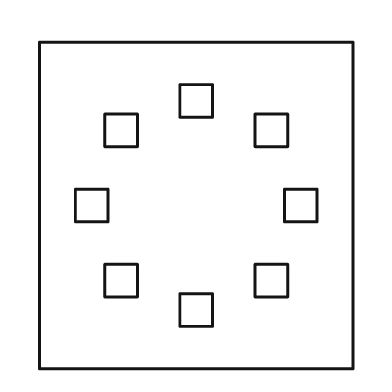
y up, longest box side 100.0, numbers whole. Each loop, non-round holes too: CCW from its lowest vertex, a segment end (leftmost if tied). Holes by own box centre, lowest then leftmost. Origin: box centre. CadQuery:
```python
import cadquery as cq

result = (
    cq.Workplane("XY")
    .moveTo(-48.0, -50.0)
    .lineTo(48.0, -50.0)
    .lineTo(48.0, 50.0)
    .lineTo(-48.0, 50.0)
    .close()
    .moveTo(-5.0, -37.0)
    .lineTo(5.0, -37.0)
    .lineTo(5.0, -27.0)
    .lineTo(-5.0, -27.0)
    .close()
    .moveTo(-28.0, -28.0)
    .lineTo(-18.0, -28.0)
    .lineTo(-18.0, -18.0)
    .lineTo(-28.0, -18.0)
    .close()
    .moveTo(18.0, -28.0)
    .lineTo(28.0, -28.0)
    .lineTo(28.0, -18.0)
    .lineTo(18.0, -18.0)
    .close()
    .moveTo(-37.0, -5.0)
    .lineTo(-27.0, -5.0)
    .lineTo(-27.0, 5.0)
    .lineTo(-37.0, 5.0)
    .close()
    .moveTo(27.0, -5.0)
    .lineTo(37.0, -5.0)
    .lineTo(37.0, 5.0)
    .lineTo(27.0, 5.0)
    .close()
    .moveTo(-28.0, 18.0)
    .lineTo(-18.0, 18.0)
    .lineTo(-18.0, 28.0)
    .lineTo(-28.0, 28.0)
    .close()
    .moveTo(18.0, 18.0)
    .lineTo(28.0, 18.0)
    .lineTo(28.0, 28.0)
    .lineTo(18.0, 28.0)
    .close()
    .moveTo(-5.0, 27.0)
    .lineTo(5.0, 27.0)
    .lineTo(5.0, 37.0)
    .lineTo(-5.0, 37.0)
    .close()
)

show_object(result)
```